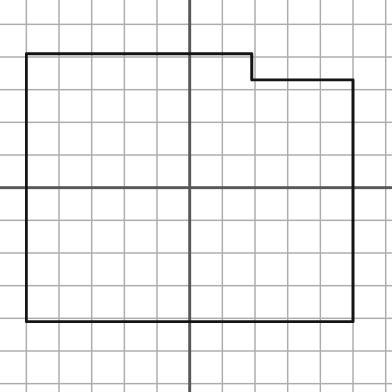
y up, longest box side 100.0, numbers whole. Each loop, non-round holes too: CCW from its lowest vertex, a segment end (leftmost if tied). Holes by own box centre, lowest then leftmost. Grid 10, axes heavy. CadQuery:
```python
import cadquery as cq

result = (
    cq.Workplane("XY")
    .moveTo(-50.0, -41.0)
    .lineTo(50.0, -41.0)
    .lineTo(50.0, 33.0)
    .lineTo(19.0, 33.0)
    .lineTo(19.0, 41.0)
    .lineTo(-50.0, 41.0)
    .close()
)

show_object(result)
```